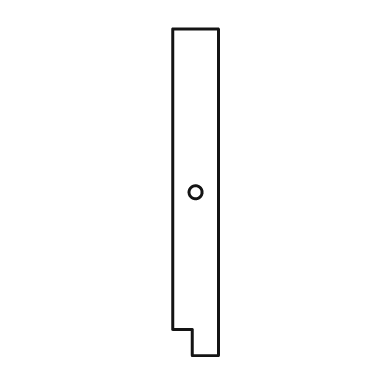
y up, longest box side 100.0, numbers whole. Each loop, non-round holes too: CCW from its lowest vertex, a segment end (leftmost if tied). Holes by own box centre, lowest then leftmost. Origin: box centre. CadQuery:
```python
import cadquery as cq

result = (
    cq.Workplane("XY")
    .moveTo(-1.0, -50.0)
    .lineTo(7.0, -50.0)
    .lineTo(7.0, 50.0)
    .lineTo(-7.0, 50.0)
    .lineTo(-7.0, -42.0)
    .lineTo(-1.0, -42.0)
    .close()
    .moveTo(0.0, 0.0)
    .circle(2.0)
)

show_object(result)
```